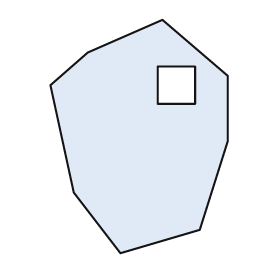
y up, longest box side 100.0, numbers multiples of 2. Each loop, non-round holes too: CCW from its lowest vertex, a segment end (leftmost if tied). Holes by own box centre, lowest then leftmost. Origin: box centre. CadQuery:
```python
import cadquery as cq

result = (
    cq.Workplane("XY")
    .moveTo(-8.0, -50.0)
    .lineTo(26.0, -40.0)
    .lineTo(38.0, -2.0)
    .lineTo(38.0, 26.0)
    .lineTo(10.0, 50.0)
    .lineTo(-22.0, 36.0)
    .lineTo(-38.0, 22.0)
    .lineTo(-28.0, -24.0)
    .close()
    .moveTo(8.0, 14.0)
    .lineTo(24.0, 14.0)
    .lineTo(24.0, 30.0)
    .lineTo(8.0, 30.0)
    .close()
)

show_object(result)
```